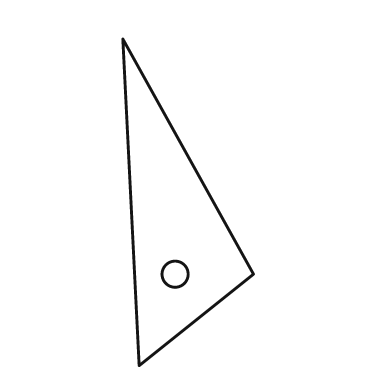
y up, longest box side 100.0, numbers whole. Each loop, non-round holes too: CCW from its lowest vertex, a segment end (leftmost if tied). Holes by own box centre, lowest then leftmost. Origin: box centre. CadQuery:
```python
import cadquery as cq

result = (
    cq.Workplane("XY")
    .moveTo(-15.0, -50.0)
    .lineTo(20.0, -22.0)
    .lineTo(-20.0, 50.0)
    .close()
    .moveTo(-4.0, -22.0)
    .circle(4.0)
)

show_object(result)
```